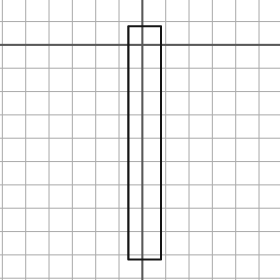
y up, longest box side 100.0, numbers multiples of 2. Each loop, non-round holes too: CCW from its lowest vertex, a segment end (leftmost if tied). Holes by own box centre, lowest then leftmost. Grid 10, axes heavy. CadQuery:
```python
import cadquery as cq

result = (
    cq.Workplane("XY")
    .moveTo(-6.0, -92.0)
    .lineTo(8.0, -92.0)
    .lineTo(8.0, 8.0)
    .lineTo(-6.0, 8.0)
    .close()
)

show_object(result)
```